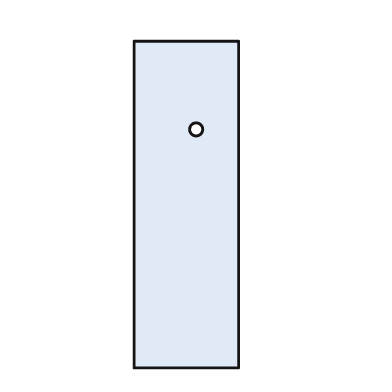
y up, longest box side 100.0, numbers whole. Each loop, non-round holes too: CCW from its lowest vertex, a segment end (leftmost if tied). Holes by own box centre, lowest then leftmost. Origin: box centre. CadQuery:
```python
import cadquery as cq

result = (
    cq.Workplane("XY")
    .moveTo(-16.0, -50.0)
    .lineTo(16.0, -50.0)
    .lineTo(16.0, 50.0)
    .lineTo(-16.0, 50.0)
    .close()
    .moveTo(3.0, 23.0)
    .circle(2.0)
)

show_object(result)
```